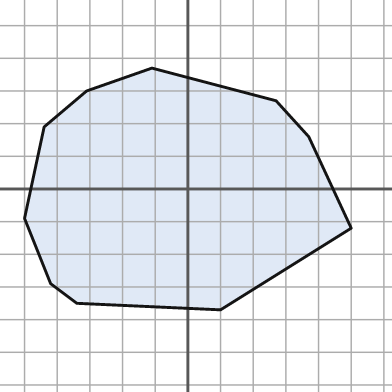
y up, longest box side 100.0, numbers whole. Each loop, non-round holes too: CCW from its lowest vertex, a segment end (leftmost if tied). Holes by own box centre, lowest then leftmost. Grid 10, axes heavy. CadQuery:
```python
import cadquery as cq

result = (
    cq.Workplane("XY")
    .moveTo(10.0, -37.0)
    .lineTo(50.0, -12.0)
    .lineTo(37.0, 16.0)
    .lineTo(27.0, 27.0)
    .lineTo(-11.0, 37.0)
    .lineTo(-31.0, 30.0)
    .lineTo(-44.0, 19.0)
    .lineTo(-50.0, -9.0)
    .lineTo(-42.0, -29.0)
    .lineTo(-34.0, -35.0)
    .close()
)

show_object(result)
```